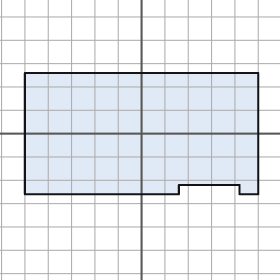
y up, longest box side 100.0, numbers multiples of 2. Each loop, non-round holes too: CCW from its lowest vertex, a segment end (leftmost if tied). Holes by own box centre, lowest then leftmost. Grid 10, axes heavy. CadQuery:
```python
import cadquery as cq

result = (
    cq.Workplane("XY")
    .moveTo(-50.0, -26.0)
    .lineTo(16.0, -26.0)
    .lineTo(16.0, -22.0)
    .lineTo(42.0, -22.0)
    .lineTo(42.0, -26.0)
    .lineTo(50.0, -26.0)
    .lineTo(50.0, 26.0)
    .lineTo(-50.0, 26.0)
    .close()
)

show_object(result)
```